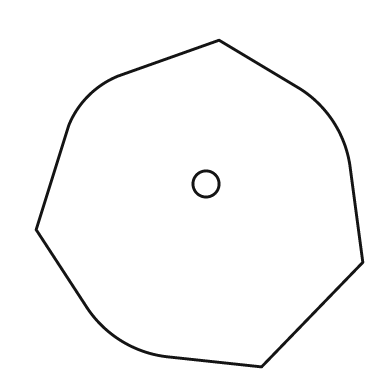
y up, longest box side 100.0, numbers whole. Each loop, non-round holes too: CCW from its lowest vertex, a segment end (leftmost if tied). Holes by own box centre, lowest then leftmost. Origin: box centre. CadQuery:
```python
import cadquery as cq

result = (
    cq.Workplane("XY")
    .moveTo(19.0, -50.0)
    .lineTo(50.0, -18.0)
    .lineTo(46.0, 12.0)
    .threePointArc((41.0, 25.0), (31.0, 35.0))
    .lineTo(6.0, 50.0)
    .lineTo(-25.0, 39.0)
    .threePointArc((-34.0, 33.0), (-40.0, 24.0))
    .lineTo(-50.0, -8.0)
    .lineTo(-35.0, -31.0)
    .threePointArc((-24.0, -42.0), (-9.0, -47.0))
    .close()
    .moveTo(2.0, 6.0)
    .circle(4.0)
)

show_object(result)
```